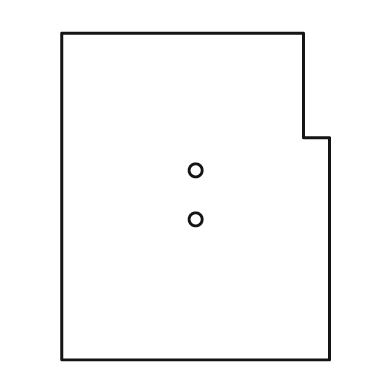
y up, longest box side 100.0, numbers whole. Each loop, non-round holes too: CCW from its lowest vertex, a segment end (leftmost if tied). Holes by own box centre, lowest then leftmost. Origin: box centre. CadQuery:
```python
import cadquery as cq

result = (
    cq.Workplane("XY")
    .moveTo(-41.0, -50.0)
    .lineTo(41.0, -50.0)
    .lineTo(41.0, 18.0)
    .lineTo(33.0, 18.0)
    .lineTo(33.0, 50.0)
    .lineTo(-41.0, 50.0)
    .close()
    .moveTo(0.0, -7.0)
    .circle(2.0)
    .moveTo(0.0, 8.0)
    .circle(2.0)
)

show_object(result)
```